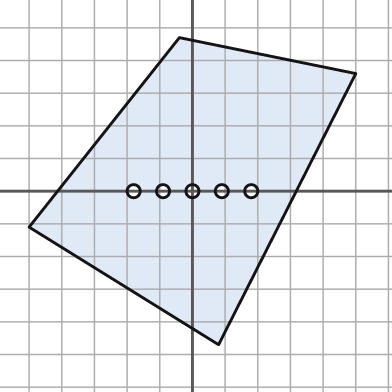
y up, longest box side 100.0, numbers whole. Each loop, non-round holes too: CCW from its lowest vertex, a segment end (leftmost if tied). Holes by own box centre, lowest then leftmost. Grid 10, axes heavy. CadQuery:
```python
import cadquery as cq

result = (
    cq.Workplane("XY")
    .moveTo(8.0, -47.0)
    .lineTo(50.0, 36.0)
    .lineTo(-4.0, 47.0)
    .lineTo(-50.0, -11.0)
    .close()
    .moveTo(-18.0, 0.0)
    .circle(2.0)
    .moveTo(-9.0, 0.0)
    .circle(2.0)
    .moveTo(0.0, 0.0)
    .circle(2.0)
    .moveTo(9.0, 0.0)
    .circle(2.0)
    .moveTo(18.0, 0.0)
    .circle(2.0)
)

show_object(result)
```